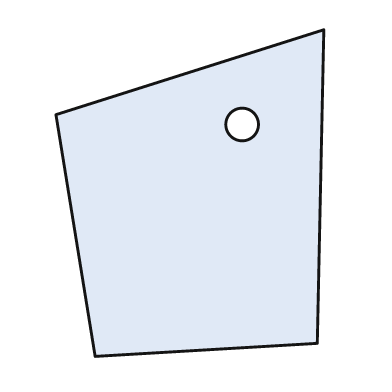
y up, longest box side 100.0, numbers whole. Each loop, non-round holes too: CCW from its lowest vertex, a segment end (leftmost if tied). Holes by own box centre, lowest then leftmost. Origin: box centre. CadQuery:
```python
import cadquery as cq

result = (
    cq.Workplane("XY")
    .moveTo(-29.0, -50.0)
    .lineTo(39.0, -46.0)
    .lineTo(41.0, 50.0)
    .lineTo(-41.0, 24.0)
    .close()
    .moveTo(16.0, 21.0)
    .circle(5.0)
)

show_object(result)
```